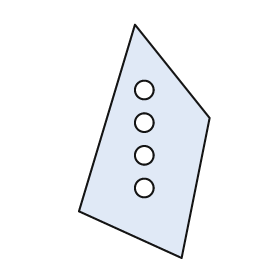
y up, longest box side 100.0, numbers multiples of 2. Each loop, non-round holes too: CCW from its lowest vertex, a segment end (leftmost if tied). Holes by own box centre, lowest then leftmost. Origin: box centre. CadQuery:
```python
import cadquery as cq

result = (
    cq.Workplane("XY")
    .moveTo(16.0, -50.0)
    .lineTo(28.0, 10.0)
    .lineTo(-4.0, 50.0)
    .lineTo(-28.0, -30.0)
    .close()
    .moveTo(0.0, -20.0)
    .circle(4.0)
    .moveTo(0.0, -6.0)
    .circle(4.0)
    .moveTo(0.0, 8.0)
    .circle(4.0)
    .moveTo(0.0, 22.0)
    .circle(4.0)
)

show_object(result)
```